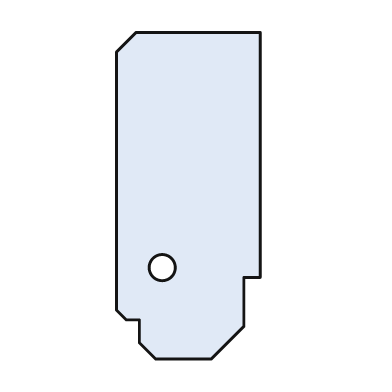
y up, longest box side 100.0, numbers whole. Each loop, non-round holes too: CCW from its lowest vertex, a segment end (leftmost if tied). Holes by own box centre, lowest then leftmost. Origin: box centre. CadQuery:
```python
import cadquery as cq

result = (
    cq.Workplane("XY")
    .moveTo(-10.0, -50.0)
    .lineTo(7.0, -50.0)
    .lineTo(17.0, -40.0)
    .lineTo(17.0, -25.0)
    .lineTo(22.0, -25.0)
    .lineTo(22.0, 50.0)
    .lineTo(-16.0, 50.0)
    .lineTo(-22.0, 44.0)
    .lineTo(-22.0, -35.0)
    .lineTo(-19.0, -38.0)
    .lineTo(-15.0, -38.0)
    .lineTo(-15.0, -45.0)
    .close()
    .moveTo(-8.0, -22.0)
    .circle(4.0)
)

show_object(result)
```